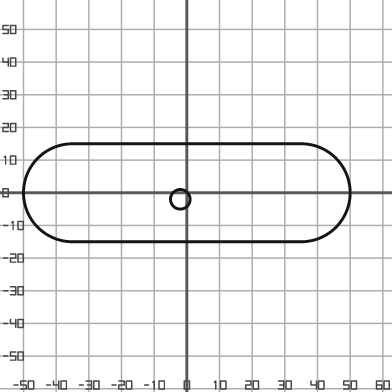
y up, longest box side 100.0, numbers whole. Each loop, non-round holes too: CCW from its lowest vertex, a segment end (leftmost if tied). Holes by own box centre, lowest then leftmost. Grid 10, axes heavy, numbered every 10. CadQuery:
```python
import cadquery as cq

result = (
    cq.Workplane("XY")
    .moveTo(-35.0, -15.0)
    .lineTo(35.0, -15.0)
    .threePointArc((50.0, 0.0), (35.0, 15.0))
    .lineTo(-35.0, 15.0)
    .threePointArc((-50.0, 0.0), (-35.0, -15.0))
    .close()
    .moveTo(-2.0, -2.0)
    .circle(3.0)
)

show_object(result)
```